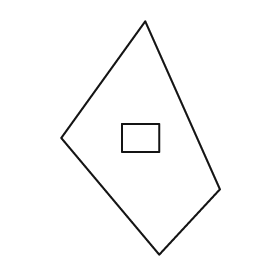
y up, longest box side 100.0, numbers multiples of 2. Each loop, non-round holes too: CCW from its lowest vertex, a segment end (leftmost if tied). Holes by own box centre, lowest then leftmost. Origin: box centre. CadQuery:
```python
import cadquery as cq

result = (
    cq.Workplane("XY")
    .moveTo(8.0, -50.0)
    .lineTo(34.0, -22.0)
    .lineTo(2.0, 50.0)
    .lineTo(-34.0, 0.0)
    .close()
    .moveTo(-8.0, -6.0)
    .lineTo(8.0, -6.0)
    .lineTo(8.0, 6.0)
    .lineTo(-8.0, 6.0)
    .close()
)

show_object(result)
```